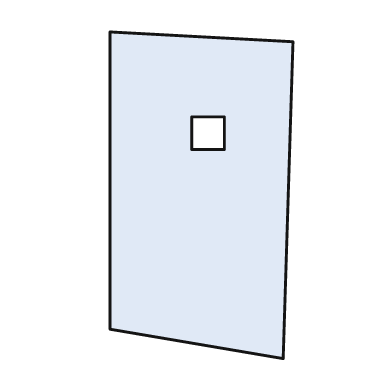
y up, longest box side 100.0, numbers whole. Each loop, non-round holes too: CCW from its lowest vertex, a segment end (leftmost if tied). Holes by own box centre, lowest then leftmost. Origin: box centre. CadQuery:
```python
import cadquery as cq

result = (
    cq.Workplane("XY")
    .moveTo(25.0, -50.0)
    .lineTo(28.0, 47.0)
    .lineTo(-28.0, 50.0)
    .lineTo(-28.0, -41.0)
    .close()
    .moveTo(-3.0, 14.0)
    .lineTo(7.0, 14.0)
    .lineTo(7.0, 24.0)
    .lineTo(-3.0, 24.0)
    .close()
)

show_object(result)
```